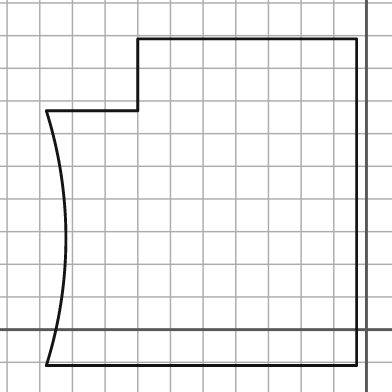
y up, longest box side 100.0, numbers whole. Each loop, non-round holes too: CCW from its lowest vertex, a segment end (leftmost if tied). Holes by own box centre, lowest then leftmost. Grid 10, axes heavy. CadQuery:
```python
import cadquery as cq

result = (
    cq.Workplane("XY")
    .moveTo(-98.0, -11.0)
    .lineTo(-3.0, -11.0)
    .lineTo(-3.0, 89.0)
    .lineTo(-70.0, 89.0)
    .lineTo(-70.0, 67.0)
    .lineTo(-98.0, 67.0)
    .threePointArc((-92.0, 28.0), (-98.0, -11.0))
    .close()
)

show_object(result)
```